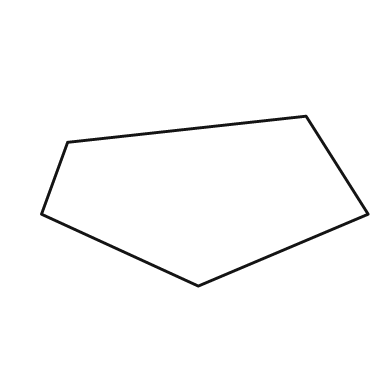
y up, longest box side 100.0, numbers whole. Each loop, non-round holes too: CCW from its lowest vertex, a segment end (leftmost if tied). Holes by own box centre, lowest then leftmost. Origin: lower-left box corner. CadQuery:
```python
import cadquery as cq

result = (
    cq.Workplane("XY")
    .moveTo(48.0, 0.0)
    .lineTo(100.0, 22.0)
    .lineTo(81.0, 52.0)
    .lineTo(8.0, 44.0)
    .lineTo(0.0, 22.0)
    .close()
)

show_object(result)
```